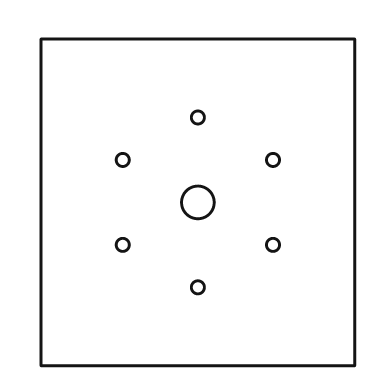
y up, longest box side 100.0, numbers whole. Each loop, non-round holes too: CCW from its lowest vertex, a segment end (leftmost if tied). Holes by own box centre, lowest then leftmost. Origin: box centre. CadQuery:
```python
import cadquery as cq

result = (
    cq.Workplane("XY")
    .moveTo(-48.0, -50.0)
    .lineTo(48.0, -50.0)
    .lineTo(48.0, 50.0)
    .lineTo(-48.0, 50.0)
    .close()
    .moveTo(0.0, -26.0)
    .circle(2.0)
    .moveTo(-23.0, -13.0)
    .circle(2.0)
    .moveTo(23.0, -13.0)
    .circle(2.0)
    .moveTo(0.0, 0.0)
    .circle(5.0)
    .moveTo(-23.0, 13.0)
    .circle(2.0)
    .moveTo(23.0, 13.0)
    .circle(2.0)
    .moveTo(0.0, 26.0)
    .circle(2.0)
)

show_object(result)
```